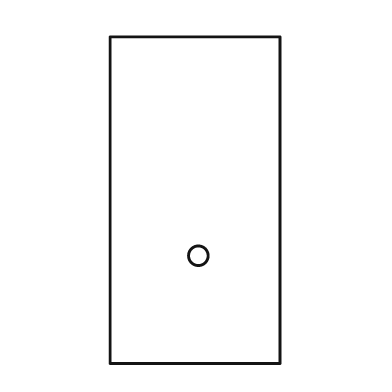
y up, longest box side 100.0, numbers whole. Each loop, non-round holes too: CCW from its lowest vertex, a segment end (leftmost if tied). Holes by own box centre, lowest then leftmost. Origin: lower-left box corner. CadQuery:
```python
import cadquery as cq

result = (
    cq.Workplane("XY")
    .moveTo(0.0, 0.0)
    .lineTo(52.0, 0.0)
    .lineTo(52.0, 100.0)
    .lineTo(0.0, 100.0)
    .close()
    .moveTo(27.0, 33.0)
    .circle(3.0)
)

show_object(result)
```